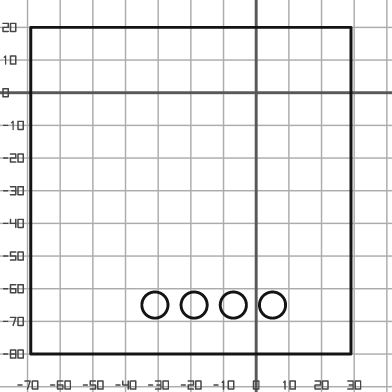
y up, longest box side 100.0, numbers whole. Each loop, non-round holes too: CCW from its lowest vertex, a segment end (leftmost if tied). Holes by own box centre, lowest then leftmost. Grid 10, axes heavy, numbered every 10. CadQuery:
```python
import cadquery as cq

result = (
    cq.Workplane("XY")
    .moveTo(-69.0, -80.0)
    .lineTo(29.0, -80.0)
    .lineTo(29.0, 20.0)
    .lineTo(-69.0, 20.0)
    .close()
    .moveTo(-31.0, -65.0)
    .circle(4.0)
    .moveTo(-19.0, -65.0)
    .circle(4.0)
    .moveTo(-7.0, -65.0)
    .circle(4.0)
    .moveTo(5.0, -65.0)
    .circle(4.0)
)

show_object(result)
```